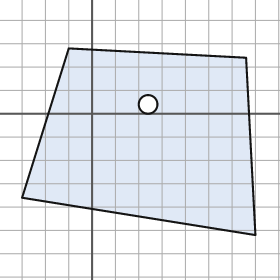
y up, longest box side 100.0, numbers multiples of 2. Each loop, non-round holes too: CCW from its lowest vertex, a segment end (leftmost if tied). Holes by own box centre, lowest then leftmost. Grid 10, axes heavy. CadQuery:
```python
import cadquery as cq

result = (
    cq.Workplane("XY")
    .moveTo(70.0, -52.0)
    .lineTo(66.0, 24.0)
    .lineTo(-10.0, 28.0)
    .lineTo(-30.0, -36.0)
    .close()
    .moveTo(24.0, 4.0)
    .circle(4.0)
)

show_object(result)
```